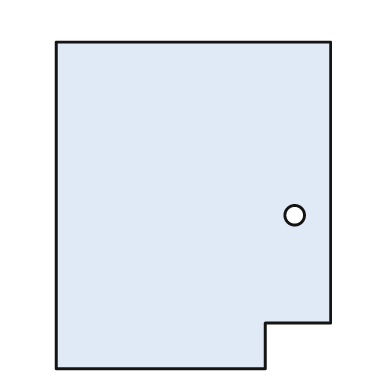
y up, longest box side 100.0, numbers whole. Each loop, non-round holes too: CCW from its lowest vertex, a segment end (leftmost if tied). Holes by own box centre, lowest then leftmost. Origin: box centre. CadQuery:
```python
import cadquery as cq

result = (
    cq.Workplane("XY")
    .moveTo(-42.0, -50.0)
    .lineTo(22.0, -50.0)
    .lineTo(22.0, -36.0)
    .lineTo(42.0, -36.0)
    .lineTo(42.0, 50.0)
    .lineTo(-42.0, 50.0)
    .close()
    .moveTo(31.0, -3.0)
    .circle(3.0)
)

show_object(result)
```